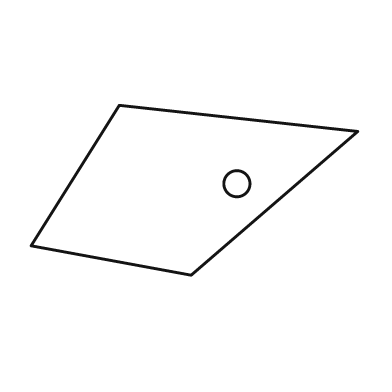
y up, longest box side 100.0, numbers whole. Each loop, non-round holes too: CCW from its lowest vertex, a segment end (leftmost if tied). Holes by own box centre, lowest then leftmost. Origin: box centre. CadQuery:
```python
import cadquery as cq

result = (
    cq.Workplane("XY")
    .moveTo(-1.0, -26.0)
    .lineTo(50.0, 18.0)
    .lineTo(-23.0, 26.0)
    .lineTo(-50.0, -17.0)
    .close()
    .moveTo(13.0, 2.0)
    .circle(4.0)
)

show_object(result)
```